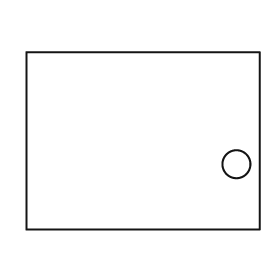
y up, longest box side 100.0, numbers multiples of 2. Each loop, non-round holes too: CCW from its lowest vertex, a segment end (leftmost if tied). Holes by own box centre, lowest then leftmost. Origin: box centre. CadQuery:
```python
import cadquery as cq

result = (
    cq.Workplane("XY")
    .moveTo(-50.0, -38.0)
    .lineTo(50.0, -38.0)
    .lineTo(50.0, 38.0)
    .lineTo(-50.0, 38.0)
    .close()
    .moveTo(40.0, -10.0)
    .circle(6.0)
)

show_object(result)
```